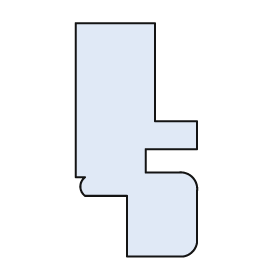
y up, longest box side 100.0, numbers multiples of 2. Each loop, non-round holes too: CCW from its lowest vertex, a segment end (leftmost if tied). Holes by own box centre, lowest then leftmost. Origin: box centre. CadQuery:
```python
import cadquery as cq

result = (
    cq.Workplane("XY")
    .moveTo(-4.0, -50.0)
    .lineTo(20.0, -50.0)
    .threePointArc((24.0, -48.0), (26.0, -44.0))
    .lineTo(26.0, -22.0)
    .threePointArc((24.0, -16.0), (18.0, -14.0))
    .lineTo(4.0, -14.0)
    .lineTo(4.0, -4.0)
    .lineTo(26.0, -4.0)
    .lineTo(26.0, 8.0)
    .lineTo(8.0, 8.0)
    .lineTo(8.0, 50.0)
    .lineTo(-26.0, 50.0)
    .lineTo(-26.0, -16.0)
    .lineTo(-22.0, -16.0)
    .threePointArc((-24.0, -20.0), (-22.0, -24.0))
    .lineTo(-4.0, -24.0)
    .close()
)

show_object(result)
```